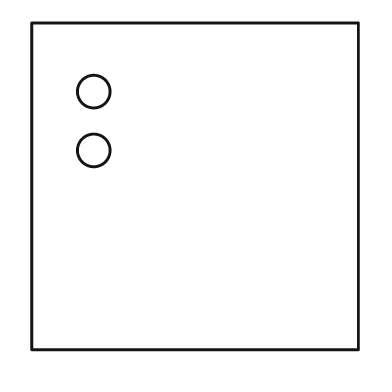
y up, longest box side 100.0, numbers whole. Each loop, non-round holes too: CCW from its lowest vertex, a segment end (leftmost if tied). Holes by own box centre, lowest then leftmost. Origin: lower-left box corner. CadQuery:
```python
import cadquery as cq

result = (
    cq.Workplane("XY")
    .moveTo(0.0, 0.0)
    .lineTo(100.0, 0.0)
    .lineTo(100.0, 100.0)
    .lineTo(0.0, 100.0)
    .close()
    .moveTo(19.0, 61.0)
    .circle(5.0)
    .moveTo(19.0, 79.0)
    .circle(5.0)
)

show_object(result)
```